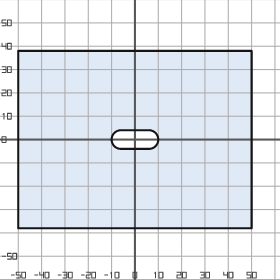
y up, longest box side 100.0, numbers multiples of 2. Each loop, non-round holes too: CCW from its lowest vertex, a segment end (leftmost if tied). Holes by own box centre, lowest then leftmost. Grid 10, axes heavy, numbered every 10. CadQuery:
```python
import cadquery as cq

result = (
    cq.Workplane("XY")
    .moveTo(-50.0, -38.0)
    .lineTo(50.0, -38.0)
    .lineTo(50.0, 38.0)
    .lineTo(-50.0, 38.0)
    .close()
    .moveTo(-6.0, -4.0)
    .lineTo(6.0, -4.0)
    .threePointArc((10.0, 0.0), (6.0, 4.0))
    .lineTo(-6.0, 4.0)
    .threePointArc((-10.0, 0.0), (-6.0, -4.0))
    .close()
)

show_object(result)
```